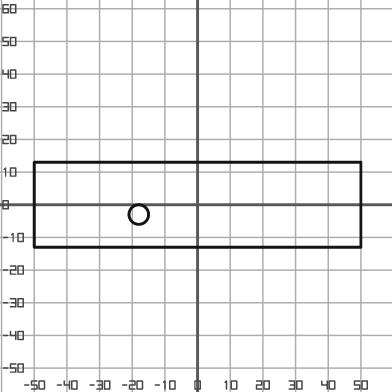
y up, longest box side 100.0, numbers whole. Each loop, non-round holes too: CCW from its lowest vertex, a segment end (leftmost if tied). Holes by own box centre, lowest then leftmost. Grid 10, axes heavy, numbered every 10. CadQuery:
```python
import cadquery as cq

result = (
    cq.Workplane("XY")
    .moveTo(-50.0, -13.0)
    .lineTo(50.0, -13.0)
    .lineTo(50.0, 13.0)
    .lineTo(-50.0, 13.0)
    .close()
    .moveTo(-18.0, -3.0)
    .circle(3.0)
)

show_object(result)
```